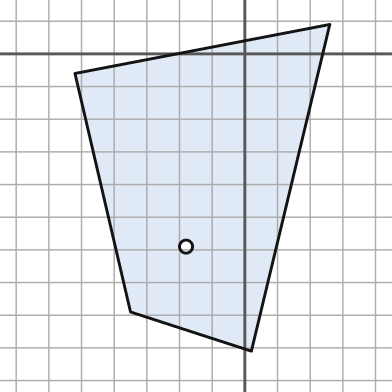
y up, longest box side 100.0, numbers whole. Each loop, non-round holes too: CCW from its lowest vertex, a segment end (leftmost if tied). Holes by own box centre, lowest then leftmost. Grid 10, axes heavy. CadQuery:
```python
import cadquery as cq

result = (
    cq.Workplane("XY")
    .moveTo(2.0, -91.0)
    .lineTo(26.0, 9.0)
    .lineTo(-52.0, -6.0)
    .lineTo(-35.0, -79.0)
    .close()
    .moveTo(-18.0, -59.0)
    .circle(2.0)
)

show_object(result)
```